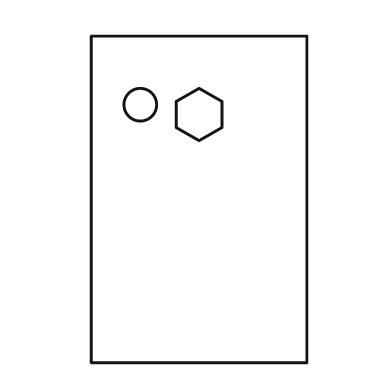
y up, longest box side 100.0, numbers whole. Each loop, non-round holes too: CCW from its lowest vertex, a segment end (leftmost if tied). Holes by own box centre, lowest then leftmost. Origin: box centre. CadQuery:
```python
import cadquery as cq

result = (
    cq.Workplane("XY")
    .moveTo(-33.0, -50.0)
    .lineTo(33.0, -50.0)
    .lineTo(33.0, 50.0)
    .lineTo(-33.0, 50.0)
    .close()
    .moveTo(0.0, 18.0)
    .lineTo(7.0, 22.0)
    .lineTo(7.0, 30.0)
    .lineTo(0.0, 34.0)
    .lineTo(-7.0, 30.0)
    .lineTo(-7.0, 22.0)
    .close()
    .moveTo(-18.0, 29.0)
    .circle(5.0)
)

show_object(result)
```